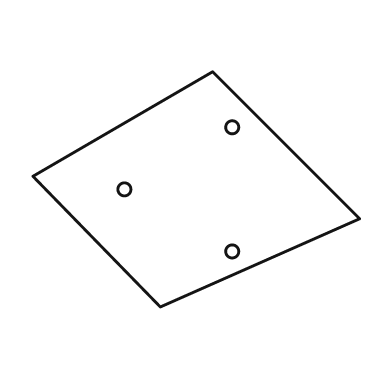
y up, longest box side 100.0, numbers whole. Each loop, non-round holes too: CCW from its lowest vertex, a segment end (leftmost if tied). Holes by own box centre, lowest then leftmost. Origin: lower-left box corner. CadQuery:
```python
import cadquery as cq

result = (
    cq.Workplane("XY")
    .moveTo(39.0, 0.0)
    .lineTo(100.0, 27.0)
    .lineTo(55.0, 72.0)
    .lineTo(0.0, 40.0)
    .close()
    .moveTo(61.0, 17.0)
    .circle(2.0)
    .moveTo(28.0, 36.0)
    .circle(2.0)
    .moveTo(61.0, 55.0)
    .circle(2.0)
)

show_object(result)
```